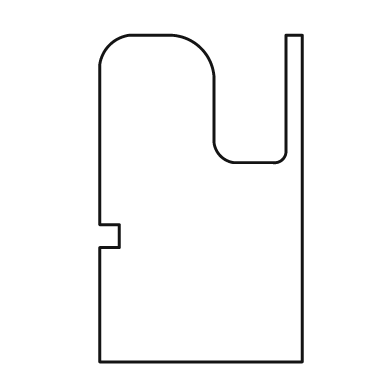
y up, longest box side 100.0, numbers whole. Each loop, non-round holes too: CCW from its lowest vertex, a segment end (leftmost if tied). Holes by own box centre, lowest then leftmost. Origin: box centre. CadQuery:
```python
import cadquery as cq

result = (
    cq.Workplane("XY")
    .moveTo(-31.0, -50.0)
    .lineTo(31.0, -50.0)
    .lineTo(31.0, 50.0)
    .lineTo(26.0, 50.0)
    .lineTo(26.0, 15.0)
    .threePointArc((25.0, 12.0), (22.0, 11.0))
    .lineTo(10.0, 11.0)
    .threePointArc((6.0, 13.0), (4.0, 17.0))
    .lineTo(4.0, 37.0)
    .threePointArc((0.0, 46.0), (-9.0, 50.0))
    .lineTo(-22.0, 50.0)
    .threePointArc((-28.0, 47.0), (-31.0, 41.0))
    .lineTo(-31.0, -8.0)
    .lineTo(-25.0, -8.0)
    .lineTo(-25.0, -15.0)
    .lineTo(-31.0, -15.0)
    .close()
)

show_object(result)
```